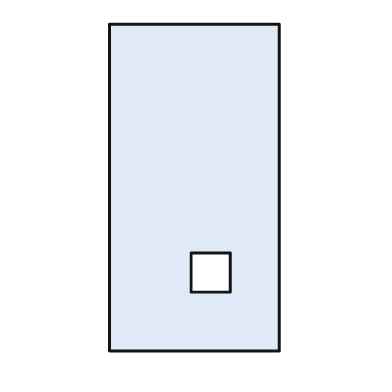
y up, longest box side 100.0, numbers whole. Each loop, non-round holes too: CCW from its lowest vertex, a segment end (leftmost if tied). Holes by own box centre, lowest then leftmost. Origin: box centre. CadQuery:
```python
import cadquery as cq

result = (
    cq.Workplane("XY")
    .moveTo(-26.0, -50.0)
    .lineTo(26.0, -50.0)
    .lineTo(26.0, 50.0)
    .lineTo(-26.0, 50.0)
    .close()
    .moveTo(-1.0, -32.0)
    .lineTo(11.0, -32.0)
    .lineTo(11.0, -20.0)
    .lineTo(-1.0, -20.0)
    .close()
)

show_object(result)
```